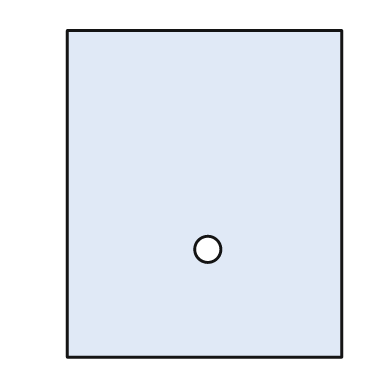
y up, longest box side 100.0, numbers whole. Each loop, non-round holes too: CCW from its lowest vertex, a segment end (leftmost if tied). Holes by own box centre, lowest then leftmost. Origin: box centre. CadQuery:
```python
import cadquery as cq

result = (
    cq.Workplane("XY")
    .moveTo(-42.0, -50.0)
    .lineTo(42.0, -50.0)
    .lineTo(42.0, 50.0)
    .lineTo(-42.0, 50.0)
    .close()
    .moveTo(1.0, -17.0)
    .circle(4.0)
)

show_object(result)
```